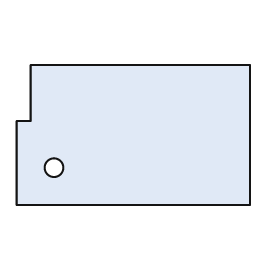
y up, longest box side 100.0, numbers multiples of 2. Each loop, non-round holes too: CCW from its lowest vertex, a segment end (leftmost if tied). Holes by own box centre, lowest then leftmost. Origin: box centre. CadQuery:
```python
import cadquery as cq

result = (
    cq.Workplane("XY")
    .moveTo(-50.0, -30.0)
    .lineTo(50.0, -30.0)
    .lineTo(50.0, 30.0)
    .lineTo(-44.0, 30.0)
    .lineTo(-44.0, 6.0)
    .lineTo(-50.0, 6.0)
    .close()
    .moveTo(-34.0, -14.0)
    .circle(4.0)
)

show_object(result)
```